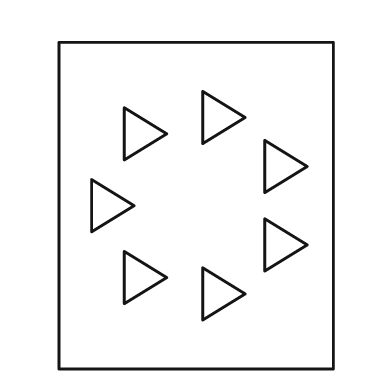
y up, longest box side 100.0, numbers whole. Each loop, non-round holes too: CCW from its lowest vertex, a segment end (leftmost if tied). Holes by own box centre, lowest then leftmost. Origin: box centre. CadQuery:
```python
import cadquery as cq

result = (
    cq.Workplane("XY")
    .moveTo(-42.0, -50.0)
    .lineTo(42.0, -50.0)
    .lineTo(42.0, 50.0)
    .lineTo(-42.0, 50.0)
    .close()
    .moveTo(2.0, -35.0)
    .lineTo(15.0, -27.0)
    .lineTo(2.0, -19.0)
    .close()
    .moveTo(-22.0, -30.0)
    .lineTo(-9.0, -22.0)
    .lineTo(-22.0, -14.0)
    .close()
    .moveTo(21.0, -20.0)
    .lineTo(34.0, -12.0)
    .lineTo(21.0, -4.0)
    .close()
    .moveTo(-32.0, -8.0)
    .lineTo(-19.0, 0.0)
    .lineTo(-32.0, 8.0)
    .close()
    .moveTo(21.0, 4.0)
    .lineTo(34.0, 12.0)
    .lineTo(21.0, 20.0)
    .close()
    .moveTo(-22.0, 14.0)
    .lineTo(-9.0, 22.0)
    .lineTo(-22.0, 30.0)
    .close()
    .moveTo(2.0, 19.0)
    .lineTo(15.0, 27.0)
    .lineTo(2.0, 35.0)
    .close()
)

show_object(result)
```